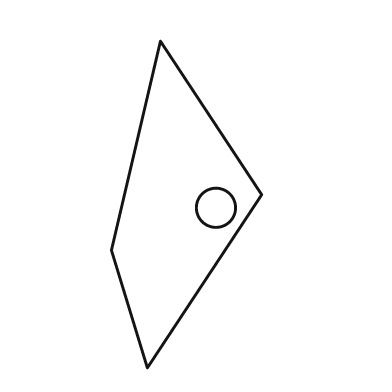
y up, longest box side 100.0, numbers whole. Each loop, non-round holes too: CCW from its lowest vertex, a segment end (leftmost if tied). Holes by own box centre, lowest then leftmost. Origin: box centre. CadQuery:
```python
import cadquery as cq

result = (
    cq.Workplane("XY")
    .moveTo(-12.0, -50.0)
    .lineTo(23.0, 3.0)
    .lineTo(-8.0, 50.0)
    .lineTo(-23.0, -14.0)
    .close()
    .moveTo(9.0, -1.0)
    .circle(6.0)
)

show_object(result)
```